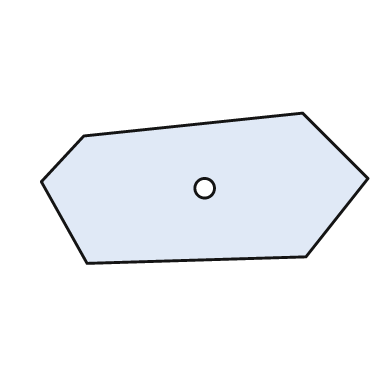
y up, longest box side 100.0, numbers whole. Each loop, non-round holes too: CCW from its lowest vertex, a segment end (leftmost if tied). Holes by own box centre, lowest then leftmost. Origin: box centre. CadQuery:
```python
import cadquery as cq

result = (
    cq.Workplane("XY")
    .moveTo(-36.0, -23.0)
    .lineTo(31.0, -21.0)
    .lineTo(50.0, 3.0)
    .lineTo(30.0, 23.0)
    .lineTo(-37.0, 16.0)
    .lineTo(-50.0, 2.0)
    .close()
    .moveTo(0.0, 0.0)
    .circle(3.0)
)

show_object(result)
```